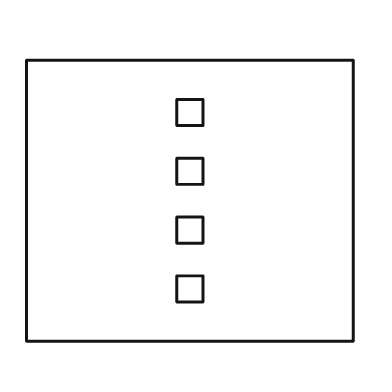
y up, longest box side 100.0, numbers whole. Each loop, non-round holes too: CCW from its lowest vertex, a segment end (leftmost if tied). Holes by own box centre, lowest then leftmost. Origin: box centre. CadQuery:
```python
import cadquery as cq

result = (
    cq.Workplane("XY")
    .moveTo(-50.0, -43.0)
    .lineTo(50.0, -43.0)
    .lineTo(50.0, 43.0)
    .lineTo(-50.0, 43.0)
    .close()
    .moveTo(-4.0, -31.0)
    .lineTo(4.0, -31.0)
    .lineTo(4.0, -23.0)
    .lineTo(-4.0, -23.0)
    .close()
    .moveTo(-4.0, -13.0)
    .lineTo(4.0, -13.0)
    .lineTo(4.0, -5.0)
    .lineTo(-4.0, -5.0)
    .close()
    .moveTo(-4.0, 5.0)
    .lineTo(4.0, 5.0)
    .lineTo(4.0, 13.0)
    .lineTo(-4.0, 13.0)
    .close()
    .moveTo(-4.0, 23.0)
    .lineTo(4.0, 23.0)
    .lineTo(4.0, 31.0)
    .lineTo(-4.0, 31.0)
    .close()
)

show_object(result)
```